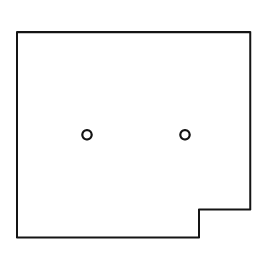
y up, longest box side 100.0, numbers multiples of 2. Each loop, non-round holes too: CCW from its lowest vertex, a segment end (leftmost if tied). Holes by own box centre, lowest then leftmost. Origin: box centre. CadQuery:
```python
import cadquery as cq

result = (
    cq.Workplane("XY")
    .moveTo(-50.0, -44.0)
    .lineTo(28.0, -44.0)
    .lineTo(28.0, -32.0)
    .lineTo(50.0, -32.0)
    .lineTo(50.0, 44.0)
    .lineTo(-50.0, 44.0)
    .close()
    .moveTo(-20.0, 0.0)
    .circle(2.0)
    .moveTo(22.0, 0.0)
    .circle(2.0)
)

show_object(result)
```